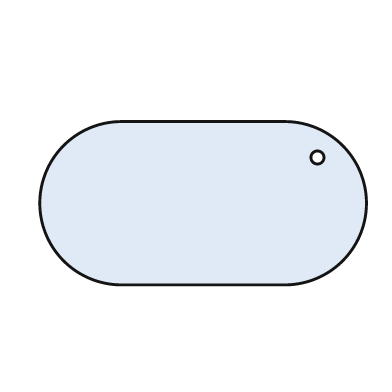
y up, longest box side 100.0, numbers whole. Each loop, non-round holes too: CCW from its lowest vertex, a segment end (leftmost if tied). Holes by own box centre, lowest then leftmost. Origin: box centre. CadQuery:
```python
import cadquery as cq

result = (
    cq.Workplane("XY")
    .moveTo(-25.0, -25.0)
    .lineTo(25.0, -25.0)
    .threePointArc((50.0, 0.0), (25.0, 25.0))
    .lineTo(-25.0, 25.0)
    .threePointArc((-50.0, 0.0), (-25.0, -25.0))
    .close()
    .moveTo(35.0, 14.0)
    .circle(2.0)
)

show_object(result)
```